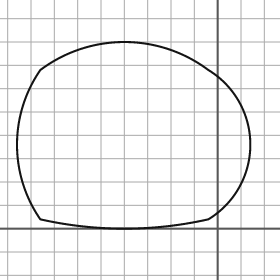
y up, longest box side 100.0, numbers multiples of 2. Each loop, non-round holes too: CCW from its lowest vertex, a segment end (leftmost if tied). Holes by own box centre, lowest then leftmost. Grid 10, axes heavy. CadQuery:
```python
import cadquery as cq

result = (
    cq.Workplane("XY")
    .moveTo(-76.0, 4.0)
    .threePointArc((-40.0, 0.0), (-4.0, 4.0))
    .threePointArc((14.0, 36.0), (-4.0, 68.0))
    .threePointArc((-40.0, 80.0), (-76.0, 68.0))
    .threePointArc((-86.0, 36.0), (-76.0, 4.0))
    .close()
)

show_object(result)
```